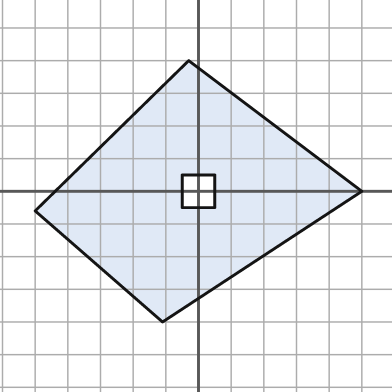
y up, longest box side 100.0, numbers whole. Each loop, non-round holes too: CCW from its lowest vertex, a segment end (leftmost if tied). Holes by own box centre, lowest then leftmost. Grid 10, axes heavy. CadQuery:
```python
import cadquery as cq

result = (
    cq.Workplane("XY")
    .moveTo(-11.0, -40.0)
    .lineTo(50.0, 0.0)
    .lineTo(-3.0, 40.0)
    .lineTo(-50.0, -6.0)
    .close()
    .moveTo(-5.0, -5.0)
    .lineTo(5.0, -5.0)
    .lineTo(5.0, 5.0)
    .lineTo(-5.0, 5.0)
    .close()
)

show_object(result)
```